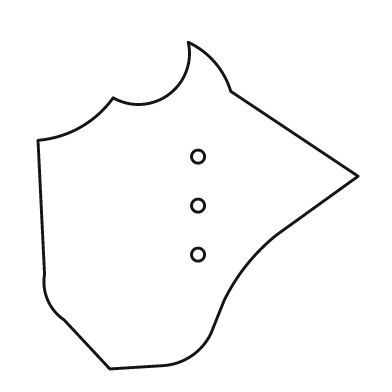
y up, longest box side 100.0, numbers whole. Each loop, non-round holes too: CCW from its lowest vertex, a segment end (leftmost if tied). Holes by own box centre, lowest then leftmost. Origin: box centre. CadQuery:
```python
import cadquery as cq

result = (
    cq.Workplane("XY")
    .moveTo(-27.0, -50.0)
    .lineTo(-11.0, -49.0)
    .threePointArc((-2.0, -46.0), (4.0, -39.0))
    .lineTo(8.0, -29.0)
    .threePointArc((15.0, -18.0), (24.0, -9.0))
    .lineTo(49.0, 9.0)
    .lineTo(10.0, 35.0)
    .threePointArc((5.0, 44.0), (-3.0, 50.0))
    .threePointArc((-9.0, 34.0), (-26.0, 33.0))
    .threePointArc((-36.0, 24.0), (-49.0, 20.0))
    .lineTo(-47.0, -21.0)
    .threePointArc((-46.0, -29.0), (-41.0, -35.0))
    .close()
    .moveTo(0.0, -15.0)
    .circle(2.0)
    .moveTo(0.0, 0.0)
    .circle(2.0)
    .moveTo(0.0, 15.0)
    .circle(2.0)
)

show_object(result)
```